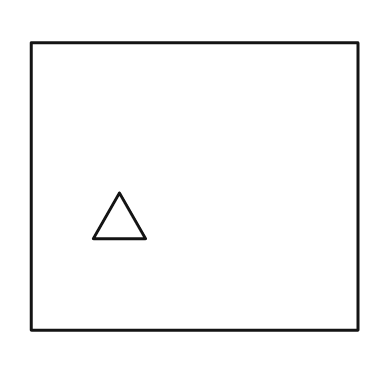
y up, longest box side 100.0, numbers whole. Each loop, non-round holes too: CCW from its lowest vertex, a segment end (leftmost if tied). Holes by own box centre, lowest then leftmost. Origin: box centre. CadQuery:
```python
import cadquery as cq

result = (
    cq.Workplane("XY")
    .moveTo(-50.0, -44.0)
    .lineTo(50.0, -44.0)
    .lineTo(50.0, 44.0)
    .lineTo(-50.0, 44.0)
    .close()
    .moveTo(-31.0, -16.0)
    .lineTo(-15.0, -16.0)
    .lineTo(-23.0, -2.0)
    .close()
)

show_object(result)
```